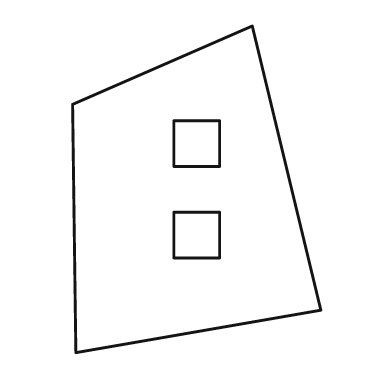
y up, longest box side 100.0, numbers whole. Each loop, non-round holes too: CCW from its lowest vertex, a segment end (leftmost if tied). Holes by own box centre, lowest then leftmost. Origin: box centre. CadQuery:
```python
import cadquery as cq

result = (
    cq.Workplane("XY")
    .moveTo(-37.0, -50.0)
    .lineTo(38.0, -37.0)
    .lineTo(17.0, 50.0)
    .lineTo(-38.0, 26.0)
    .close()
    .moveTo(-7.0, -21.0)
    .lineTo(7.0, -21.0)
    .lineTo(7.0, -7.0)
    .lineTo(-7.0, -7.0)
    .close()
    .moveTo(-7.0, 7.0)
    .lineTo(7.0, 7.0)
    .lineTo(7.0, 21.0)
    .lineTo(-7.0, 21.0)
    .close()
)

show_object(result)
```